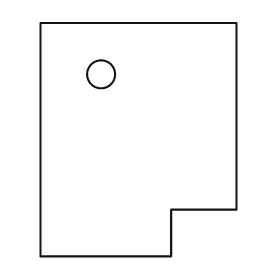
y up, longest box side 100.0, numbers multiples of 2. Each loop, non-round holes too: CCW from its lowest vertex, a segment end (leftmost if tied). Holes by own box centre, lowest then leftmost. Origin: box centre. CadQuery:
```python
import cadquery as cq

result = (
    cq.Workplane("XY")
    .moveTo(-42.0, -50.0)
    .lineTo(14.0, -50.0)
    .lineTo(14.0, -30.0)
    .lineTo(42.0, -30.0)
    .lineTo(42.0, 50.0)
    .lineTo(-42.0, 50.0)
    .close()
    .moveTo(-16.0, 28.0)
    .circle(6.0)
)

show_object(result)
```